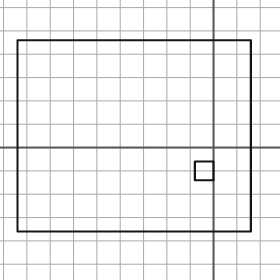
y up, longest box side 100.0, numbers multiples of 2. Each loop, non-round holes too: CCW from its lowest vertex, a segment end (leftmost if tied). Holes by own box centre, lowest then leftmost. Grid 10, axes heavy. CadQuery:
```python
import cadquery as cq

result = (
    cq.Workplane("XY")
    .moveTo(-84.0, -36.0)
    .lineTo(16.0, -36.0)
    .lineTo(16.0, 46.0)
    .lineTo(-84.0, 46.0)
    .close()
    .moveTo(-8.0, -14.0)
    .lineTo(0.0, -14.0)
    .lineTo(0.0, -6.0)
    .lineTo(-8.0, -6.0)
    .close()
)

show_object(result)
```